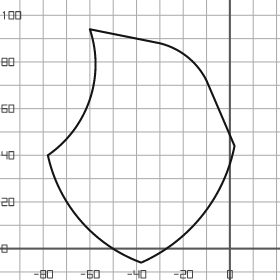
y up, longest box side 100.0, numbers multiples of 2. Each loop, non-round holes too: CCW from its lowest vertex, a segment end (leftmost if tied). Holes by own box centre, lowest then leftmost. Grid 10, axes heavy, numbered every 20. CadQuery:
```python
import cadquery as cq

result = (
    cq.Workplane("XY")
    .moveTo(-38.0, -6.0)
    .threePointArc((-12.0, 14.0), (2.0, 44.0))
    .lineTo(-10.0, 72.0)
    .threePointArc((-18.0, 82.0), (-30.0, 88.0))
    .lineTo(-60.0, 94.0)
    .threePointArc((-60.0, 64.0), (-78.0, 40.0))
    .threePointArc((-64.0, 12.0), (-38.0, -6.0))
    .close()
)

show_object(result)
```